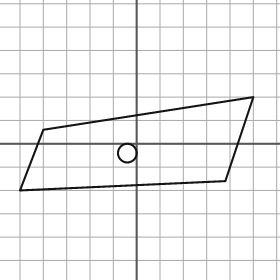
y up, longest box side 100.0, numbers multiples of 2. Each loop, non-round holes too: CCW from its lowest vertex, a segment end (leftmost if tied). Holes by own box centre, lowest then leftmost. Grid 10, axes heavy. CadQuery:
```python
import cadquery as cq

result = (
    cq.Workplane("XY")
    .moveTo(-50.0, -20.0)
    .lineTo(38.0, -16.0)
    .lineTo(50.0, 20.0)
    .lineTo(-40.0, 6.0)
    .close()
    .moveTo(-4.0, -4.0)
    .circle(4.0)
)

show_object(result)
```